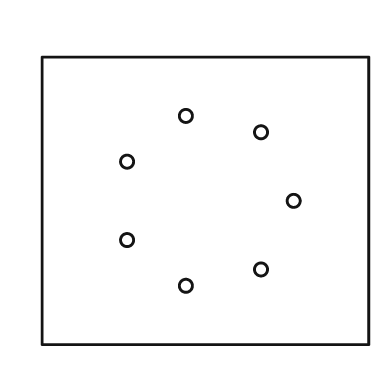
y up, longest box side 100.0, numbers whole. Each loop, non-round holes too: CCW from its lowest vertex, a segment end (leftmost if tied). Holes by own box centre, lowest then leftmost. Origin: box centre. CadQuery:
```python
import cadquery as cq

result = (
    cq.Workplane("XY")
    .moveTo(-50.0, -44.0)
    .lineTo(50.0, -44.0)
    .lineTo(50.0, 44.0)
    .lineTo(-50.0, 44.0)
    .close()
    .moveTo(-6.0, -26.0)
    .circle(2.0)
    .moveTo(17.0, -21.0)
    .circle(2.0)
    .moveTo(-24.0, -12.0)
    .circle(2.0)
    .moveTo(27.0, 0.0)
    .circle(2.0)
    .moveTo(-24.0, 12.0)
    .circle(2.0)
    .moveTo(17.0, 21.0)
    .circle(2.0)
    .moveTo(-6.0, 26.0)
    .circle(2.0)
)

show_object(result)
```